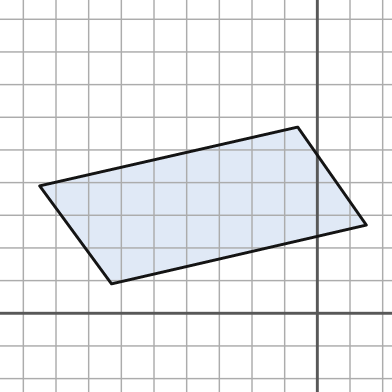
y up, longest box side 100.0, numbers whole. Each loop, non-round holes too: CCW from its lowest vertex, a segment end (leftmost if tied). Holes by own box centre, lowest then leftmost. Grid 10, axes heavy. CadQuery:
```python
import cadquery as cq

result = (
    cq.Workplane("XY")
    .moveTo(-63.0, 9.0)
    .lineTo(15.0, 27.0)
    .lineTo(-6.0, 57.0)
    .lineTo(-85.0, 39.0)
    .close()
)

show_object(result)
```